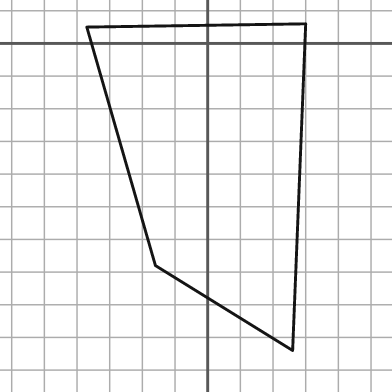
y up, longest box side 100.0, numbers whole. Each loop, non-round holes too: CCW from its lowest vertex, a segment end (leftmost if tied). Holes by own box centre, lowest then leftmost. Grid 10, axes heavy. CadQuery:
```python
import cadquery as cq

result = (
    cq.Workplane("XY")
    .moveTo(26.0, -94.0)
    .lineTo(30.0, 6.0)
    .lineTo(-37.0, 5.0)
    .lineTo(-16.0, -68.0)
    .close()
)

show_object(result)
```